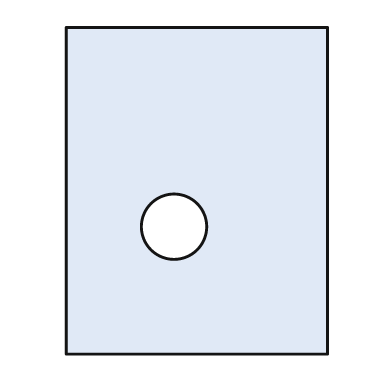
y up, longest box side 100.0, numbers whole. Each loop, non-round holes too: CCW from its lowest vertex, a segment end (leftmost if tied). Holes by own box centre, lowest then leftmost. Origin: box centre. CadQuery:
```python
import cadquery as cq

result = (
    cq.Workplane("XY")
    .moveTo(-40.0, -50.0)
    .lineTo(40.0, -50.0)
    .lineTo(40.0, 50.0)
    .lineTo(-40.0, 50.0)
    .close()
    .moveTo(-7.0, -11.0)
    .circle(10.0)
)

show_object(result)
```